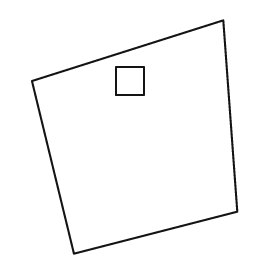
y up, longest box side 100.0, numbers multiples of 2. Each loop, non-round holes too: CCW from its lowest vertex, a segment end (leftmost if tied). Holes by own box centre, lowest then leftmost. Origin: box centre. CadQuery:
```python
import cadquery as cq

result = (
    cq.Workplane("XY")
    .moveTo(-26.0, -50.0)
    .lineTo(44.0, -32.0)
    .lineTo(38.0, 50.0)
    .lineTo(-44.0, 24.0)
    .close()
    .moveTo(-8.0, 18.0)
    .lineTo(4.0, 18.0)
    .lineTo(4.0, 30.0)
    .lineTo(-8.0, 30.0)
    .close()
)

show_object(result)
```